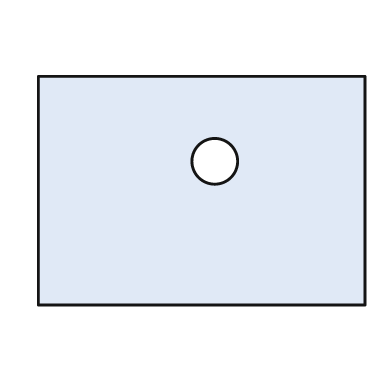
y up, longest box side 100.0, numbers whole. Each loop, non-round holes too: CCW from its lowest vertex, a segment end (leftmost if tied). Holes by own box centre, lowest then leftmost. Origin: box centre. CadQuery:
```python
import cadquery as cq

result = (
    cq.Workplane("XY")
    .moveTo(-50.0, -35.0)
    .lineTo(50.0, -35.0)
    .lineTo(50.0, 35.0)
    .lineTo(-50.0, 35.0)
    .close()
    .moveTo(4.0, 9.0)
    .circle(7.0)
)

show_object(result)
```